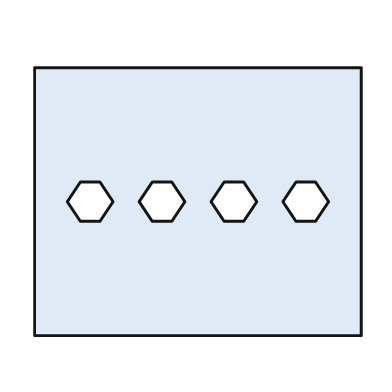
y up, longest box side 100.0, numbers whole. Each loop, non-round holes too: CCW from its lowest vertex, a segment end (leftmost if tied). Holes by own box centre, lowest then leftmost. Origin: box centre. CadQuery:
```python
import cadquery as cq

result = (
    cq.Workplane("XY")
    .moveTo(-50.0, -41.0)
    .lineTo(50.0, -41.0)
    .lineTo(50.0, 41.0)
    .lineTo(-50.0, 41.0)
    .close()
    .moveTo(-36.0, -6.0)
    .lineTo(-30.0, -6.0)
    .lineTo(-26.0, 0.0)
    .lineTo(-30.0, 6.0)
    .lineTo(-36.0, 6.0)
    .lineTo(-40.0, 0.0)
    .close()
    .moveTo(-14.0, -6.0)
    .lineTo(-8.0, -6.0)
    .lineTo(-4.0, 0.0)
    .lineTo(-8.0, 6.0)
    .lineTo(-14.0, 6.0)
    .lineTo(-18.0, 0.0)
    .close()
    .moveTo(8.0, -6.0)
    .lineTo(14.0, -6.0)
    .lineTo(18.0, 0.0)
    .lineTo(14.0, 6.0)
    .lineTo(8.0, 6.0)
    .lineTo(4.0, 0.0)
    .close()
    .moveTo(30.0, -6.0)
    .lineTo(36.0, -6.0)
    .lineTo(40.0, 0.0)
    .lineTo(36.0, 6.0)
    .lineTo(30.0, 6.0)
    .lineTo(26.0, 0.0)
    .close()
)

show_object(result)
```